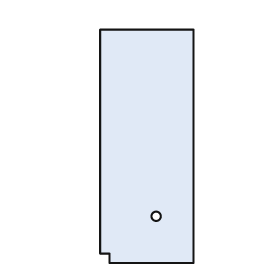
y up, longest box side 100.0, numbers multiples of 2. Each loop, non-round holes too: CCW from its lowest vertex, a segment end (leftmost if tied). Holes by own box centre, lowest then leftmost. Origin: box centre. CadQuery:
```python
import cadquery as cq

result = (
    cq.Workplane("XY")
    .moveTo(-16.0, -50.0)
    .lineTo(20.0, -50.0)
    .lineTo(20.0, 50.0)
    .lineTo(-20.0, 50.0)
    .lineTo(-20.0, -46.0)
    .lineTo(-16.0, -46.0)
    .close()
    .moveTo(4.0, -30.0)
    .circle(2.0)
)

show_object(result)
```